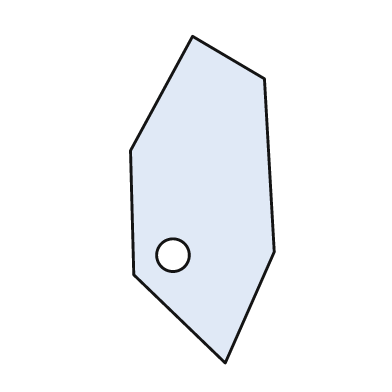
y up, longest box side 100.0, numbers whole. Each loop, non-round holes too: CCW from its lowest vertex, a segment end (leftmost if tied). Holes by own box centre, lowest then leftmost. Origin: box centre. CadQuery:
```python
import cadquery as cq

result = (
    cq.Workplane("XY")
    .moveTo(7.0, -50.0)
    .lineTo(22.0, -16.0)
    .lineTo(19.0, 37.0)
    .lineTo(-3.0, 50.0)
    .lineTo(-22.0, 15.0)
    .lineTo(-21.0, -23.0)
    .close()
    .moveTo(-9.0, -17.0)
    .circle(5.0)
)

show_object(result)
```